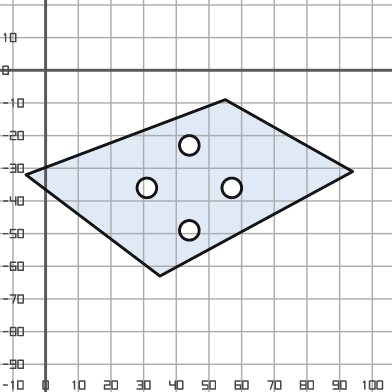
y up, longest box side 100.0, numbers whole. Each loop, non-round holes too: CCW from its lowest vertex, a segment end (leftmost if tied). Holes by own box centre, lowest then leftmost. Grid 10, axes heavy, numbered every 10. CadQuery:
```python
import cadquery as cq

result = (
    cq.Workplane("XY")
    .moveTo(35.0, -63.0)
    .lineTo(94.0, -31.0)
    .lineTo(55.0, -9.0)
    .lineTo(-6.0, -32.0)
    .close()
    .moveTo(44.0, -49.0)
    .circle(3.0)
    .moveTo(31.0, -36.0)
    .circle(3.0)
    .moveTo(57.0, -36.0)
    .circle(3.0)
    .moveTo(44.0, -23.0)
    .circle(3.0)
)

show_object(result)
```